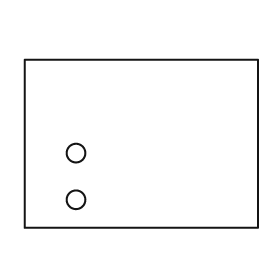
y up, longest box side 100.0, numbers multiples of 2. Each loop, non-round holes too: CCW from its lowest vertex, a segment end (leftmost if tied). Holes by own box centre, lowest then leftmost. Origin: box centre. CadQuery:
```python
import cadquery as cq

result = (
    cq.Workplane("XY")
    .moveTo(-50.0, -36.0)
    .lineTo(50.0, -36.0)
    .lineTo(50.0, 36.0)
    .lineTo(-50.0, 36.0)
    .close()
    .moveTo(-28.0, -24.0)
    .circle(4.0)
    .moveTo(-28.0, -4.0)
    .circle(4.0)
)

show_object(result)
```